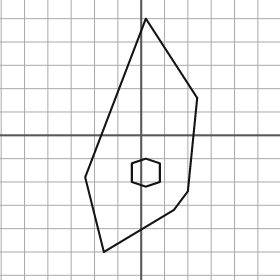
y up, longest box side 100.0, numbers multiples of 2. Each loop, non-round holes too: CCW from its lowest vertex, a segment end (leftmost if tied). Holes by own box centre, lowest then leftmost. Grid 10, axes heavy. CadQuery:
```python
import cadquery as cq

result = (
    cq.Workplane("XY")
    .moveTo(-16.0, -50.0)
    .lineTo(14.0, -32.0)
    .lineTo(20.0, -24.0)
    .lineTo(24.0, 16.0)
    .lineTo(2.0, 50.0)
    .lineTo(-24.0, -18.0)
    .close()
    .moveTo(2.0, -22.0)
    .lineTo(8.0, -20.0)
    .lineTo(8.0, -12.0)
    .lineTo(2.0, -10.0)
    .lineTo(-4.0, -12.0)
    .lineTo(-4.0, -20.0)
    .close()
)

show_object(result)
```